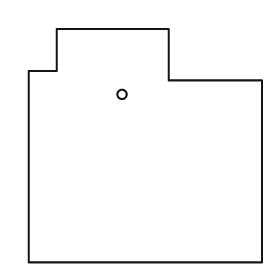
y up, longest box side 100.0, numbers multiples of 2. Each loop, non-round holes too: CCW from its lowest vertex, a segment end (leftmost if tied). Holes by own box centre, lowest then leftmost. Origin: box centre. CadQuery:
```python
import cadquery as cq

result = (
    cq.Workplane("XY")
    .moveTo(-50.0, -50.0)
    .lineTo(50.0, -50.0)
    .lineTo(50.0, 28.0)
    .lineTo(10.0, 28.0)
    .lineTo(10.0, 50.0)
    .lineTo(-38.0, 50.0)
    .lineTo(-38.0, 32.0)
    .lineTo(-50.0, 32.0)
    .close()
    .moveTo(-10.0, 22.0)
    .circle(2.0)
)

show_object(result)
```